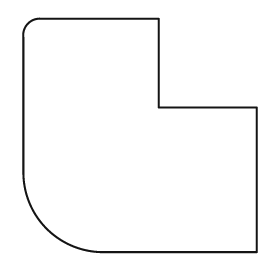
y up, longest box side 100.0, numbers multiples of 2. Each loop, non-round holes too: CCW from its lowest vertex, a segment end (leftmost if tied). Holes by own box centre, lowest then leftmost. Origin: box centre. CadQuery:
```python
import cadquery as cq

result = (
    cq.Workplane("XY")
    .moveTo(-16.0, -50.0)
    .lineTo(50.0, -50.0)
    .lineTo(50.0, 12.0)
    .lineTo(8.0, 12.0)
    .lineTo(8.0, 50.0)
    .lineTo(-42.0, 50.0)
    .threePointArc((-48.0, 48.0), (-50.0, 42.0))
    .lineTo(-50.0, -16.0)
    .threePointArc((-40.0, -40.0), (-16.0, -50.0))
    .close()
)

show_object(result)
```